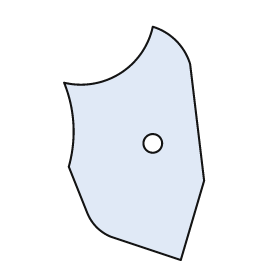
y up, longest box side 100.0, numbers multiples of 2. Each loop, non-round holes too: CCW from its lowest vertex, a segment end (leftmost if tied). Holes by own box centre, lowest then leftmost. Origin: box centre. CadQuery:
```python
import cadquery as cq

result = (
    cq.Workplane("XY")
    .moveTo(20.0, -50.0)
    .lineTo(30.0, -16.0)
    .lineTo(24.0, 34.0)
    .threePointArc((18.0, 44.0), (8.0, 50.0))
    .threePointArc((-6.0, 30.0), (-30.0, 26.0))
    .threePointArc((-26.0, 8.0), (-28.0, -10.0))
    .lineTo(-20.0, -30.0)
    .threePointArc((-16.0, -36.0), (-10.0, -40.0))
    .close()
    .moveTo(8.0, 0.0)
    .circle(4.0)
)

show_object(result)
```